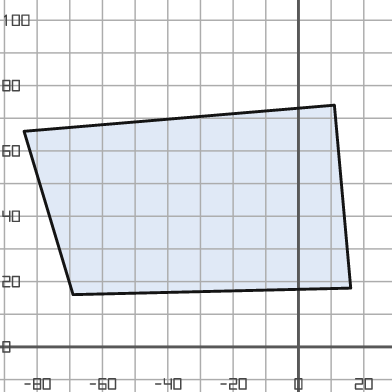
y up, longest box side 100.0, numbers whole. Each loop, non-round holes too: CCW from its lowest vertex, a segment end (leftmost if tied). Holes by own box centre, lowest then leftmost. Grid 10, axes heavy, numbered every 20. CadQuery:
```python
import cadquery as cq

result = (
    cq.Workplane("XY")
    .moveTo(-69.0, 16.0)
    .lineTo(16.0, 18.0)
    .lineTo(11.0, 74.0)
    .lineTo(-84.0, 66.0)
    .close()
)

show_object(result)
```